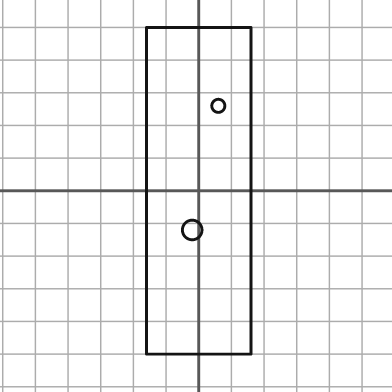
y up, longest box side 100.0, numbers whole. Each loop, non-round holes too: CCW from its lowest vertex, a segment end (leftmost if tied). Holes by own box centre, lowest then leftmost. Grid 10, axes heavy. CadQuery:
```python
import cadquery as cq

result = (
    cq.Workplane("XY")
    .moveTo(-16.0, -50.0)
    .lineTo(16.0, -50.0)
    .lineTo(16.0, 50.0)
    .lineTo(-16.0, 50.0)
    .close()
    .moveTo(-2.0, -12.0)
    .circle(3.0)
    .moveTo(6.0, 26.0)
    .circle(2.0)
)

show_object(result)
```